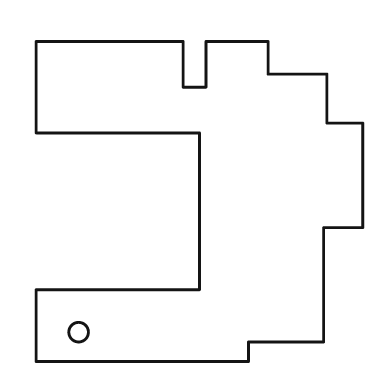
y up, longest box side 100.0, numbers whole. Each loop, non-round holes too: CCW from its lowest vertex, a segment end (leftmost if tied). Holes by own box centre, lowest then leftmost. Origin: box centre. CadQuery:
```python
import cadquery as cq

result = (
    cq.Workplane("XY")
    .moveTo(-50.0, -49.0)
    .lineTo(15.0, -49.0)
    .lineTo(15.0, -43.0)
    .lineTo(38.0, -43.0)
    .lineTo(38.0, -8.0)
    .lineTo(50.0, -8.0)
    .lineTo(50.0, 24.0)
    .lineTo(39.0, 24.0)
    .lineTo(39.0, 39.0)
    .lineTo(21.0, 39.0)
    .lineTo(21.0, 49.0)
    .lineTo(2.0, 49.0)
    .lineTo(2.0, 35.0)
    .lineTo(-5.0, 35.0)
    .lineTo(-5.0, 49.0)
    .lineTo(-50.0, 49.0)
    .lineTo(-50.0, 21.0)
    .lineTo(0.0, 21.0)
    .lineTo(0.0, -27.0)
    .lineTo(-50.0, -27.0)
    .close()
    .moveTo(-37.0, -40.0)
    .circle(3.0)
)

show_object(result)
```